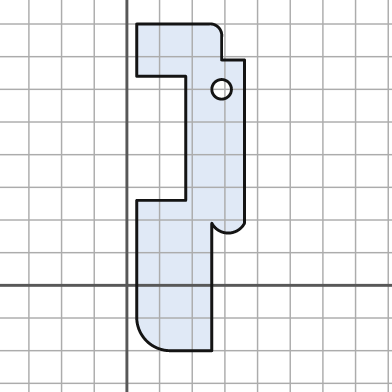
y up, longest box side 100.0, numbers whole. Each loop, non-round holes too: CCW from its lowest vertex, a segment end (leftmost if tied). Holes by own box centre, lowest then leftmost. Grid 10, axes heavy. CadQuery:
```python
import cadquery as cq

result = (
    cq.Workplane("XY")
    .moveTo(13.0, -20.0)
    .lineTo(26.0, -20.0)
    .lineTo(26.0, 19.0)
    .threePointArc((31.0, 16.0), (36.0, 19.0))
    .lineTo(36.0, 69.0)
    .lineTo(29.0, 69.0)
    .lineTo(29.0, 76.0)
    .threePointArc((28.0, 79.0), (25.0, 80.0))
    .lineTo(3.0, 80.0)
    .lineTo(3.0, 64.0)
    .lineTo(18.0, 64.0)
    .lineTo(18.0, 26.0)
    .lineTo(3.0, 26.0)
    .lineTo(3.0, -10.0)
    .threePointArc((6.0, -17.0), (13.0, -20.0))
    .close()
    .moveTo(29.0, 60.0)
    .circle(3.0)
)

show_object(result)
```